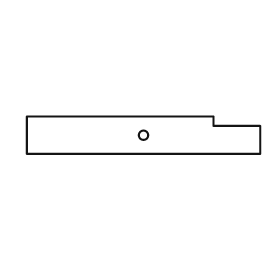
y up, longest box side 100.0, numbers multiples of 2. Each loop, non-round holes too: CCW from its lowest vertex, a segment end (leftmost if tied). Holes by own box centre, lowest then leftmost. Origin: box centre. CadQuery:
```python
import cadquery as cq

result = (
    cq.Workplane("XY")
    .moveTo(-50.0, -8.0)
    .lineTo(50.0, -8.0)
    .lineTo(50.0, 4.0)
    .lineTo(30.0, 4.0)
    .lineTo(30.0, 8.0)
    .lineTo(-50.0, 8.0)
    .close()
    .moveTo(0.0, 0.0)
    .circle(2.0)
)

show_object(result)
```